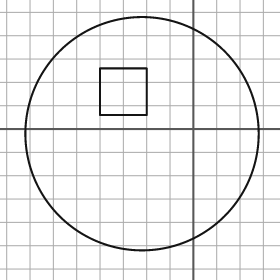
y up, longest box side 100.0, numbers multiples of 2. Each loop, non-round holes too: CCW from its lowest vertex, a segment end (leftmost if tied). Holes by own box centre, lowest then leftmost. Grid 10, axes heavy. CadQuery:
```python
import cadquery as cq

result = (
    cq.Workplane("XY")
    .moveTo(-22.0, -2.0)
    .circle(50.0)
    .moveTo(-40.0, 6.0)
    .lineTo(-20.0, 6.0)
    .lineTo(-20.0, 26.0)
    .lineTo(-40.0, 26.0)
    .close()
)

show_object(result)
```